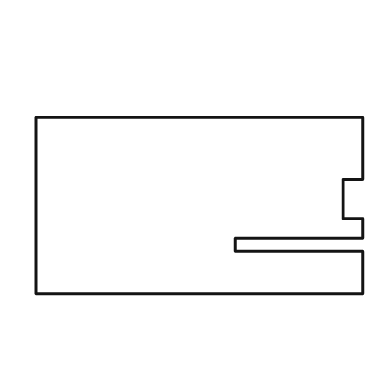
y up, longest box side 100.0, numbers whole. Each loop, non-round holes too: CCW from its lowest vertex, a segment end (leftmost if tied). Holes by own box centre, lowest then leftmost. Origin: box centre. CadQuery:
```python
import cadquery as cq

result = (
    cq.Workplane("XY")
    .moveTo(-50.0, -27.0)
    .lineTo(50.0, -27.0)
    .lineTo(50.0, -14.0)
    .lineTo(11.0, -14.0)
    .lineTo(11.0, -10.0)
    .lineTo(50.0, -10.0)
    .lineTo(50.0, -4.0)
    .lineTo(44.0, -4.0)
    .lineTo(44.0, 8.0)
    .lineTo(50.0, 8.0)
    .lineTo(50.0, 27.0)
    .lineTo(-50.0, 27.0)
    .close()
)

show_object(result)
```